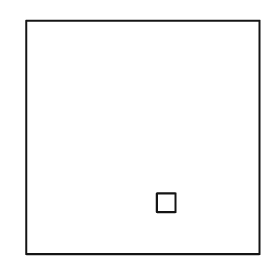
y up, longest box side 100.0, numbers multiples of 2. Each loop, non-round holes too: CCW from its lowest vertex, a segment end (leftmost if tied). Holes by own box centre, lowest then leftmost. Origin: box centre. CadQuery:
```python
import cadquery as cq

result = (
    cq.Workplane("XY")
    .moveTo(-50.0, -50.0)
    .lineTo(50.0, -50.0)
    .lineTo(50.0, 50.0)
    .lineTo(-50.0, 50.0)
    .close()
    .moveTo(6.0, -32.0)
    .lineTo(14.0, -32.0)
    .lineTo(14.0, -24.0)
    .lineTo(6.0, -24.0)
    .close()
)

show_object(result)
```